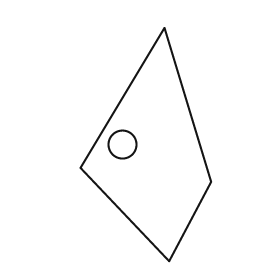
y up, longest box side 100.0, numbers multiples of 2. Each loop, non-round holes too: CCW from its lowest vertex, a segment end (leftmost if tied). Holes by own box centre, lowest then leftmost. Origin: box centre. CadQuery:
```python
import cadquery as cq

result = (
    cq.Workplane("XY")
    .moveTo(10.0, -50.0)
    .lineTo(28.0, -16.0)
    .lineTo(8.0, 50.0)
    .lineTo(-28.0, -10.0)
    .close()
    .moveTo(-10.0, 0.0)
    .circle(6.0)
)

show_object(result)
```